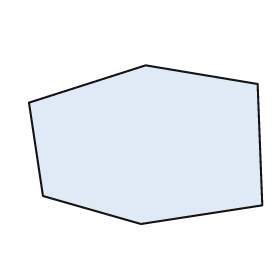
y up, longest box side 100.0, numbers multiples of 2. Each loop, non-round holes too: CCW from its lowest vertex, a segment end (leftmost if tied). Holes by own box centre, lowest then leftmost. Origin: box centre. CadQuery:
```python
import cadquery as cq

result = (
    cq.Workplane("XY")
    .moveTo(-2.0, -34.0)
    .lineTo(50.0, -26.0)
    .lineTo(48.0, 26.0)
    .lineTo(0.0, 34.0)
    .lineTo(-50.0, 18.0)
    .lineTo(-44.0, -22.0)
    .close()
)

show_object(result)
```